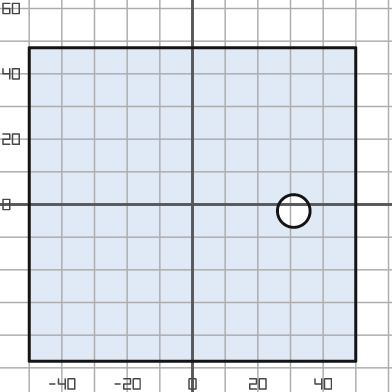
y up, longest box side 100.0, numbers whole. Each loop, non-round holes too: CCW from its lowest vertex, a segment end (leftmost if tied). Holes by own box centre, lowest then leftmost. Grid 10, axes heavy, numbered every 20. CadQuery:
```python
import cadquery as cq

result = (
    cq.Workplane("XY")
    .moveTo(-50.0, -48.0)
    .lineTo(50.0, -48.0)
    .lineTo(50.0, 48.0)
    .lineTo(-50.0, 48.0)
    .close()
    .moveTo(31.0, -2.0)
    .circle(5.0)
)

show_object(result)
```